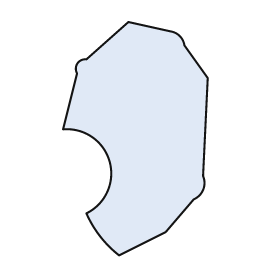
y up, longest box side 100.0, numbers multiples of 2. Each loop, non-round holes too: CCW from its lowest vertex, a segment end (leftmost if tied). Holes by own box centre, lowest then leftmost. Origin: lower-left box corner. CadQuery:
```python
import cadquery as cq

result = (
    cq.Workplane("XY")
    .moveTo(24.0, 0.0)
    .lineTo(44.0, 10.0)
    .lineTo(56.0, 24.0)
    .threePointArc((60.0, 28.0), (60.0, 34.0))
    .lineTo(62.0, 76.0)
    .lineTo(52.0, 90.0)
    .threePointArc((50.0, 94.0), (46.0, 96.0))
    .lineTo(28.0, 100.0)
    .lineTo(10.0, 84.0)
    .threePointArc((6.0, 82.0), (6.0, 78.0))
    .lineTo(0.0, 54.0)
    .threePointArc((20.0, 40.0), (10.0, 18.0))
    .threePointArc((16.0, 8.0), (24.0, 0.0))
    .close()
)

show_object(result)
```